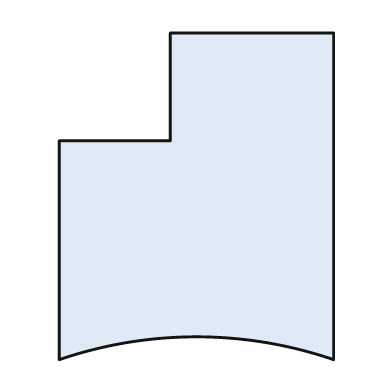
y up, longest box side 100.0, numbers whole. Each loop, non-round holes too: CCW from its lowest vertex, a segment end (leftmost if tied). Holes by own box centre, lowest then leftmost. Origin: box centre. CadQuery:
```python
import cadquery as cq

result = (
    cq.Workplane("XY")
    .moveTo(-42.0, -50.0)
    .threePointArc((0.0, -43.0), (42.0, -50.0))
    .lineTo(42.0, 50.0)
    .lineTo(-8.0, 50.0)
    .lineTo(-8.0, 17.0)
    .lineTo(-42.0, 17.0)
    .close()
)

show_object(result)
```